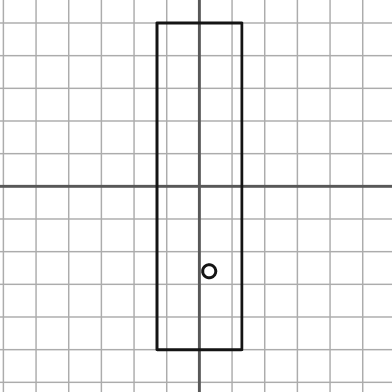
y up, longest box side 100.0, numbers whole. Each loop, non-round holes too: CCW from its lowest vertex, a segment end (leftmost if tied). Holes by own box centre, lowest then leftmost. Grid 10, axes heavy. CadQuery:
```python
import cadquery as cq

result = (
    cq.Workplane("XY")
    .moveTo(-13.0, -50.0)
    .lineTo(13.0, -50.0)
    .lineTo(13.0, 50.0)
    .lineTo(-13.0, 50.0)
    .close()
    .moveTo(3.0, -26.0)
    .circle(2.0)
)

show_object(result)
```